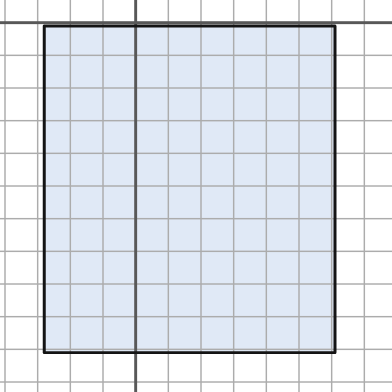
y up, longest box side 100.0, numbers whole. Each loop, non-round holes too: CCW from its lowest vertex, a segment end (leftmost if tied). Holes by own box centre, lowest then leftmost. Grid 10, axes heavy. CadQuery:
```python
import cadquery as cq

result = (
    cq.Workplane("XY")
    .moveTo(-28.0, -101.0)
    .lineTo(61.0, -101.0)
    .lineTo(61.0, -1.0)
    .lineTo(-28.0, -1.0)
    .close()
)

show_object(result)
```